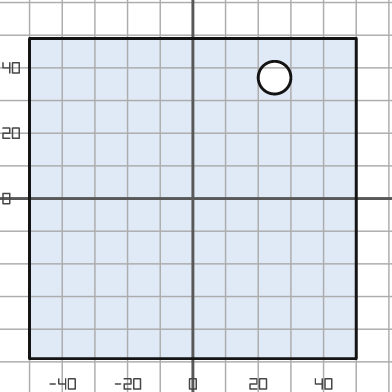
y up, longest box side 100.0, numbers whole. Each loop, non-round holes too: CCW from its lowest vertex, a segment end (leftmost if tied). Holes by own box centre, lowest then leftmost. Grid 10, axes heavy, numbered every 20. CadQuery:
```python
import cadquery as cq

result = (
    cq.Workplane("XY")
    .moveTo(-50.0, -49.0)
    .lineTo(50.0, -49.0)
    .lineTo(50.0, 49.0)
    .lineTo(-50.0, 49.0)
    .close()
    .moveTo(25.0, 37.0)
    .circle(5.0)
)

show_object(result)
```